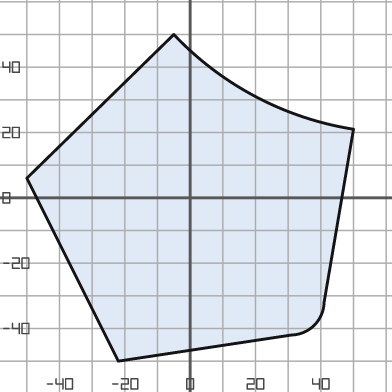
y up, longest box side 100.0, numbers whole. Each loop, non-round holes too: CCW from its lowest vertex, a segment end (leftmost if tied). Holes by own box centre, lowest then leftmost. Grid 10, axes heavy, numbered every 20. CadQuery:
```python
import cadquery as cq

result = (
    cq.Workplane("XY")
    .moveTo(-22.0, -50.0)
    .lineTo(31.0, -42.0)
    .threePointArc((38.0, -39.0), (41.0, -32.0))
    .lineTo(50.0, 21.0)
    .threePointArc((20.0, 31.0), (-5.0, 50.0))
    .lineTo(-50.0, 6.0)
    .close()
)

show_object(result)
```